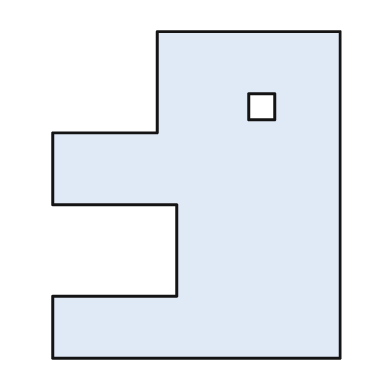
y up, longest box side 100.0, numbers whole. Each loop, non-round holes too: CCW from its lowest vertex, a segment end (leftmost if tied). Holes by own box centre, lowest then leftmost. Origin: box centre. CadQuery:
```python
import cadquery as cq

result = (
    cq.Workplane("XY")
    .moveTo(-44.0, -50.0)
    .lineTo(44.0, -50.0)
    .lineTo(44.0, 50.0)
    .lineTo(-12.0, 50.0)
    .lineTo(-12.0, 19.0)
    .lineTo(-44.0, 19.0)
    .lineTo(-44.0, -3.0)
    .lineTo(-6.0, -3.0)
    .lineTo(-6.0, -31.0)
    .lineTo(-44.0, -31.0)
    .close()
    .moveTo(16.0, 23.0)
    .lineTo(24.0, 23.0)
    .lineTo(24.0, 31.0)
    .lineTo(16.0, 31.0)
    .close()
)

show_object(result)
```